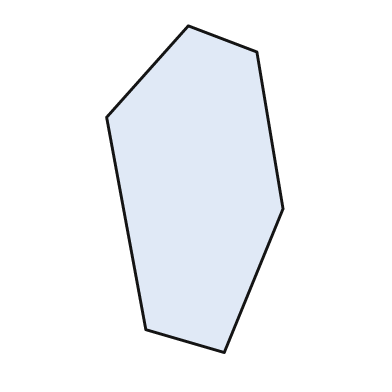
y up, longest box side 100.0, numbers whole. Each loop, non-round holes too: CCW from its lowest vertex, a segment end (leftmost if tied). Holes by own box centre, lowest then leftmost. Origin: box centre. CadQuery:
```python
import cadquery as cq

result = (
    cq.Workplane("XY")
    .moveTo(9.0, -50.0)
    .lineTo(27.0, -6.0)
    .lineTo(19.0, 42.0)
    .lineTo(-2.0, 50.0)
    .lineTo(-27.0, 22.0)
    .lineTo(-15.0, -43.0)
    .close()
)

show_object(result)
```